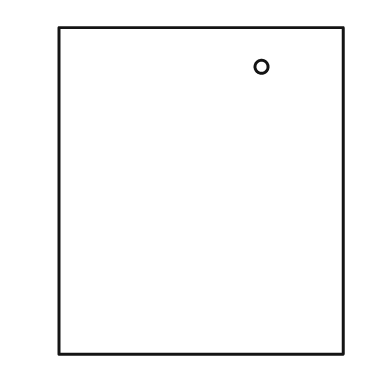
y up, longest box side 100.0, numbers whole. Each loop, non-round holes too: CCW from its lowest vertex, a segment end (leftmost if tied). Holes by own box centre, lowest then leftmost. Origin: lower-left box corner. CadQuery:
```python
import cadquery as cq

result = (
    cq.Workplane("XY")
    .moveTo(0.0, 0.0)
    .lineTo(87.0, 0.0)
    .lineTo(87.0, 100.0)
    .lineTo(0.0, 100.0)
    .close()
    .moveTo(62.0, 88.0)
    .circle(2.0)
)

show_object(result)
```